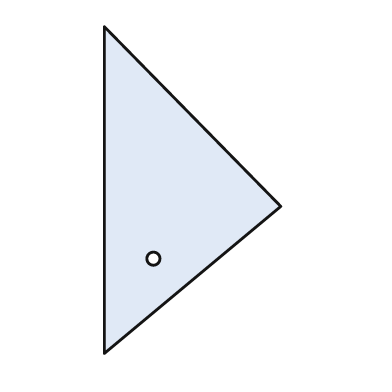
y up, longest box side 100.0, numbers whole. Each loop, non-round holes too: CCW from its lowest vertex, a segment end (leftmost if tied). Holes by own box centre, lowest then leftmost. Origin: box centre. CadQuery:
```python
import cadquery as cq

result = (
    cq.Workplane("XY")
    .moveTo(-27.0, -50.0)
    .lineTo(27.0, -5.0)
    .lineTo(-27.0, 50.0)
    .close()
    .moveTo(-12.0, -21.0)
    .circle(2.0)
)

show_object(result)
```